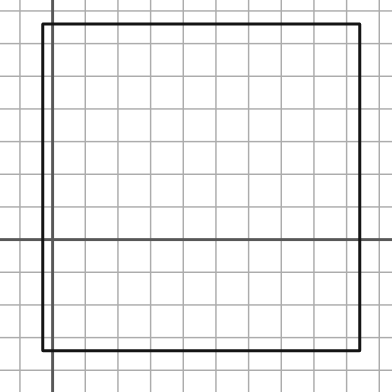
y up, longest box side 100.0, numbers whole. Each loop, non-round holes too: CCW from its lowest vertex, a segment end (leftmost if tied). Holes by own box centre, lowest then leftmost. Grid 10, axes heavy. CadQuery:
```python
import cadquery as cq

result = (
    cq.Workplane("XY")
    .moveTo(-3.0, -34.0)
    .lineTo(94.0, -34.0)
    .lineTo(94.0, 66.0)
    .lineTo(-3.0, 66.0)
    .close()
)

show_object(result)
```